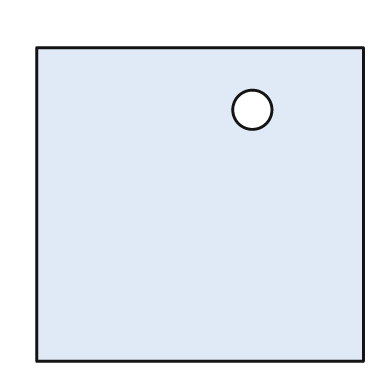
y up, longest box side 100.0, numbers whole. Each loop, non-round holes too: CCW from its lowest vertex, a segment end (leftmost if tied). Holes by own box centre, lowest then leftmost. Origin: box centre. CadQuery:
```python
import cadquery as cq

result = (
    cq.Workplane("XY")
    .moveTo(-50.0, -48.0)
    .lineTo(50.0, -48.0)
    .lineTo(50.0, 48.0)
    .lineTo(-50.0, 48.0)
    .close()
    .moveTo(16.0, 29.0)
    .circle(6.0)
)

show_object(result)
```